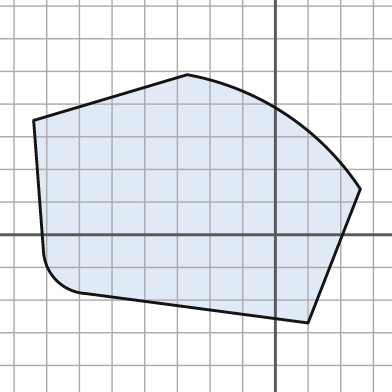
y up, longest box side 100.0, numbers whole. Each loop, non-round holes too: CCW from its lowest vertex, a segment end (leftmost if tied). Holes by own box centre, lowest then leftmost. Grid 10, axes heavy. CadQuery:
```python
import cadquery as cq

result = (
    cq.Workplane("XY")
    .moveTo(10.0, -27.0)
    .lineTo(26.0, 14.0)
    .threePointArc((3.0, 37.0), (-27.0, 49.0))
    .lineTo(-74.0, 35.0)
    .lineTo(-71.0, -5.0)
    .threePointArc((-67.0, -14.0), (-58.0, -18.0))
    .close()
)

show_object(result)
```